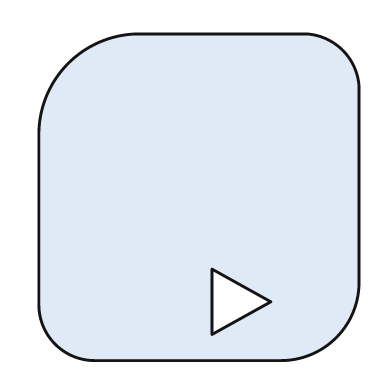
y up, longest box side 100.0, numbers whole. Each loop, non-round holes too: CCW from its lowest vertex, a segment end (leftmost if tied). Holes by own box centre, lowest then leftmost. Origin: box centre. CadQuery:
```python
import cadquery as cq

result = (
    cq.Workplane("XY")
    .moveTo(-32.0, -50.0)
    .lineTo(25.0, -50.0)
    .threePointArc((42.0, -43.0), (49.0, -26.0))
    .lineTo(49.0, 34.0)
    .threePointArc((44.0, 45.0), (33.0, 50.0))
    .lineTo(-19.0, 50.0)
    .threePointArc((-40.0, 41.0), (-49.0, 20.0))
    .lineTo(-49.0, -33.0)
    .threePointArc((-44.0, -45.0), (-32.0, -50.0))
    .close()
    .moveTo(4.0, -42.0)
    .lineTo(22.0, -32.0)
    .lineTo(4.0, -22.0)
    .close()
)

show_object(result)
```